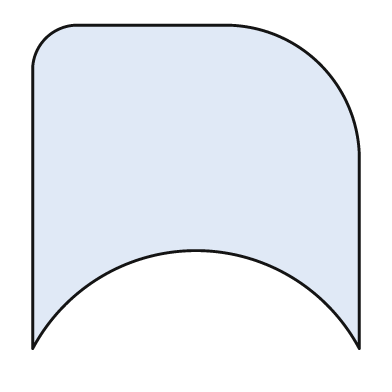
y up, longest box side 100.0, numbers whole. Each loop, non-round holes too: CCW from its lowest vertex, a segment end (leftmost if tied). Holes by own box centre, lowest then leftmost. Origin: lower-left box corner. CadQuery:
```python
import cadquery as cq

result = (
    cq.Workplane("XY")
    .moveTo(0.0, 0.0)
    .threePointArc((50.0, 30.0), (100.0, 0.0))
    .lineTo(100.0, 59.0)
    .threePointArc((88.0, 87.0), (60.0, 99.0))
    .lineTo(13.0, 99.0)
    .threePointArc((4.0, 95.0), (0.0, 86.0))
    .close()
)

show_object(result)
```